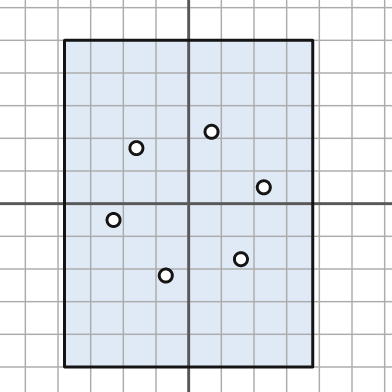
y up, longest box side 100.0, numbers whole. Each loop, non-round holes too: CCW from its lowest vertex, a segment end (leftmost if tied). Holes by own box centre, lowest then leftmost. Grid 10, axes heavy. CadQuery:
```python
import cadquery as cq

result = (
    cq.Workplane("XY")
    .moveTo(-38.0, -50.0)
    .lineTo(38.0, -50.0)
    .lineTo(38.0, 50.0)
    .lineTo(-38.0, 50.0)
    .close()
    .moveTo(-7.0, -22.0)
    .circle(2.0)
    .moveTo(16.0, -17.0)
    .circle(2.0)
    .moveTo(-23.0, -5.0)
    .circle(2.0)
    .moveTo(23.0, 5.0)
    .circle(2.0)
    .moveTo(-16.0, 17.0)
    .circle(2.0)
    .moveTo(7.0, 22.0)
    .circle(2.0)
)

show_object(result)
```